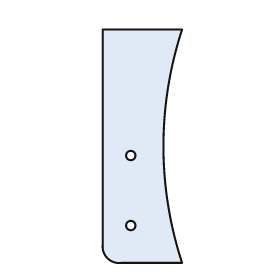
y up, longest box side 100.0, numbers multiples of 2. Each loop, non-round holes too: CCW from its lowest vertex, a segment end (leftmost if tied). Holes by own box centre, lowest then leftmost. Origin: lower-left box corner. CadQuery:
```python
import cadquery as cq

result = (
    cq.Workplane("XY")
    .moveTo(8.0, 0.0)
    .lineTo(34.0, 0.0)
    .threePointArc((26.0, 50.0), (34.0, 100.0))
    .lineTo(0.0, 100.0)
    .lineTo(0.0, 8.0)
    .threePointArc((2.0, 2.0), (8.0, 0.0))
    .close()
    .moveTo(12.0, 16.0)
    .circle(2.0)
    .moveTo(12.0, 46.0)
    .circle(2.0)
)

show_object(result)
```